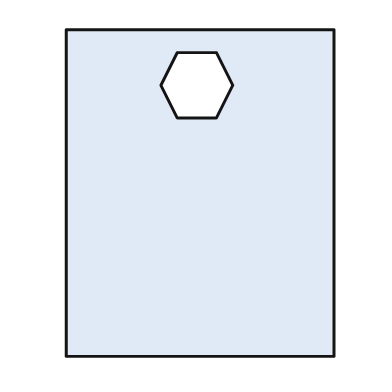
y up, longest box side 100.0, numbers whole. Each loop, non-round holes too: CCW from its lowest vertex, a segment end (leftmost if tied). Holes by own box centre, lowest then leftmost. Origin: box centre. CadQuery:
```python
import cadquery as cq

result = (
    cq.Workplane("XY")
    .moveTo(-41.0, -50.0)
    .lineTo(41.0, -50.0)
    .lineTo(41.0, 50.0)
    .lineTo(-41.0, 50.0)
    .close()
    .moveTo(-7.0, 23.0)
    .lineTo(5.0, 23.0)
    .lineTo(10.0, 33.0)
    .lineTo(5.0, 43.0)
    .lineTo(-7.0, 43.0)
    .lineTo(-12.0, 33.0)
    .close()
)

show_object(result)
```